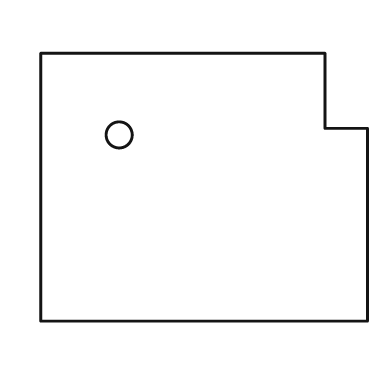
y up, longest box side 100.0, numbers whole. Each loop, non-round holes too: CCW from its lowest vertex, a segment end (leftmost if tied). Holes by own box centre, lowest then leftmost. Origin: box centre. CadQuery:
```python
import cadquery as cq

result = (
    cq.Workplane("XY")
    .moveTo(-50.0, -41.0)
    .lineTo(50.0, -41.0)
    .lineTo(50.0, 18.0)
    .lineTo(37.0, 18.0)
    .lineTo(37.0, 41.0)
    .lineTo(-50.0, 41.0)
    .close()
    .moveTo(-26.0, 16.0)
    .circle(4.0)
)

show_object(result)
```